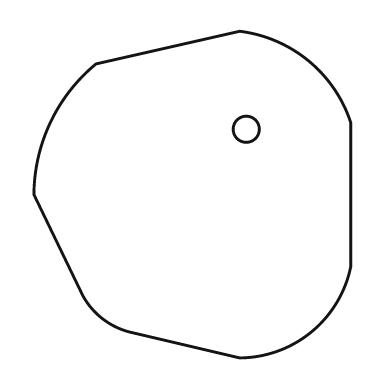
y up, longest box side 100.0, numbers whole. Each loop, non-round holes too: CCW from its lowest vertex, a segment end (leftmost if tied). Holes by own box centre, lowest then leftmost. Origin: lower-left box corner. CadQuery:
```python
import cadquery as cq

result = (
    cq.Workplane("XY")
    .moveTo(63.0, 0.0)
    .threePointArc((85.0, 8.0), (97.0, 28.0))
    .lineTo(97.0, 72.0)
    .threePointArc((84.0, 91.0), (63.0, 100.0))
    .lineTo(19.0, 90.0)
    .threePointArc((5.0, 72.0), (0.0, 50.0))
    .lineTo(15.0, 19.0)
    .threePointArc((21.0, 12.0), (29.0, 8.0))
    .close()
    .moveTo(65.0, 70.0)
    .circle(4.0)
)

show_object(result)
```